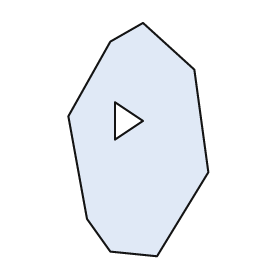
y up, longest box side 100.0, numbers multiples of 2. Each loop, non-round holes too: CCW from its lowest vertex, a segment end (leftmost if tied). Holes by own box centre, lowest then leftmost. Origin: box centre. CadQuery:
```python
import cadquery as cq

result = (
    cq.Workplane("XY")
    .moveTo(8.0, -50.0)
    .lineTo(30.0, -14.0)
    .lineTo(24.0, 30.0)
    .lineTo(2.0, 50.0)
    .lineTo(-12.0, 42.0)
    .lineTo(-30.0, 10.0)
    .lineTo(-22.0, -34.0)
    .lineTo(-12.0, -48.0)
    .close()
    .moveTo(-10.0, 0.0)
    .lineTo(2.0, 8.0)
    .lineTo(-10.0, 16.0)
    .close()
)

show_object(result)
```